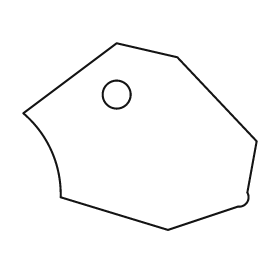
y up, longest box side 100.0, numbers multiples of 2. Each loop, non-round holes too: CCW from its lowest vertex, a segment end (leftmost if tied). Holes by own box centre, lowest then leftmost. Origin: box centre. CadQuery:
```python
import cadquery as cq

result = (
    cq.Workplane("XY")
    .moveTo(12.0, -40.0)
    .lineTo(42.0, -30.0)
    .threePointArc((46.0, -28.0), (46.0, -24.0))
    .lineTo(50.0, -2.0)
    .lineTo(16.0, 34.0)
    .lineTo(-10.0, 40.0)
    .lineTo(-50.0, 10.0)
    .threePointArc((-38.0, -6.0), (-34.0, -26.0))
    .close()
    .moveTo(-10.0, 18.0)
    .circle(6.0)
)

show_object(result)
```